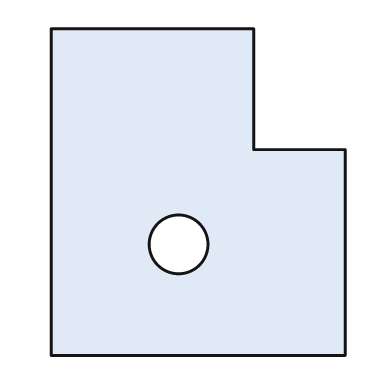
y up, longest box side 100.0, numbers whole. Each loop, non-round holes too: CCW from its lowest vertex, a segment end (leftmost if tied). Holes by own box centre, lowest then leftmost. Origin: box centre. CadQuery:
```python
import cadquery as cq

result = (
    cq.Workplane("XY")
    .moveTo(-45.0, -50.0)
    .lineTo(45.0, -50.0)
    .lineTo(45.0, 13.0)
    .lineTo(17.0, 13.0)
    .lineTo(17.0, 50.0)
    .lineTo(-45.0, 50.0)
    .close()
    .moveTo(-6.0, -16.0)
    .circle(9.0)
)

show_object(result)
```